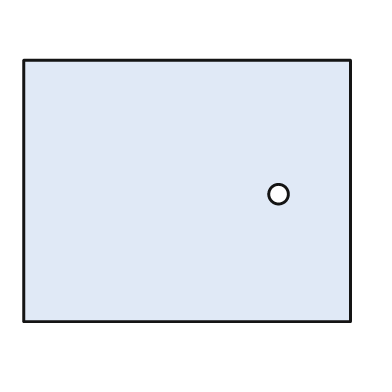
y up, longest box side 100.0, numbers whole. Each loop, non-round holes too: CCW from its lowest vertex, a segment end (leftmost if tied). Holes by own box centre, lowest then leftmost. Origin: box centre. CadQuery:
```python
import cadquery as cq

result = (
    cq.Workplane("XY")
    .moveTo(-50.0, -40.0)
    .lineTo(50.0, -40.0)
    .lineTo(50.0, 40.0)
    .lineTo(-50.0, 40.0)
    .close()
    .moveTo(28.0, -1.0)
    .circle(3.0)
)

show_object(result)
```